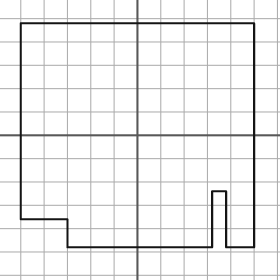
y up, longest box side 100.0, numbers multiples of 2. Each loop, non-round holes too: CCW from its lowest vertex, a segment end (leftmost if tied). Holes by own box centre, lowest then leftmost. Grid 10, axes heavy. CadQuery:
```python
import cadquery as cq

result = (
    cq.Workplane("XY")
    .moveTo(-30.0, -48.0)
    .lineTo(32.0, -48.0)
    .lineTo(32.0, -24.0)
    .lineTo(38.0, -24.0)
    .lineTo(38.0, -48.0)
    .lineTo(50.0, -48.0)
    .lineTo(50.0, 48.0)
    .lineTo(-50.0, 48.0)
    .lineTo(-50.0, -36.0)
    .lineTo(-30.0, -36.0)
    .close()
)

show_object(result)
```